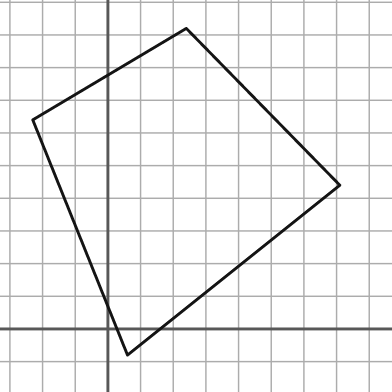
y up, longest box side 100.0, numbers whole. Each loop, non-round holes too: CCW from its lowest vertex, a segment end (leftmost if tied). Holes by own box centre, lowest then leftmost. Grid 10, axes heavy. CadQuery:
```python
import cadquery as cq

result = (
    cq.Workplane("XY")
    .moveTo(6.0, -8.0)
    .lineTo(71.0, 44.0)
    .lineTo(24.0, 92.0)
    .lineTo(-23.0, 64.0)
    .close()
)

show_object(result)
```